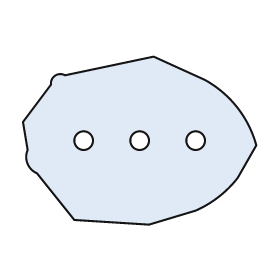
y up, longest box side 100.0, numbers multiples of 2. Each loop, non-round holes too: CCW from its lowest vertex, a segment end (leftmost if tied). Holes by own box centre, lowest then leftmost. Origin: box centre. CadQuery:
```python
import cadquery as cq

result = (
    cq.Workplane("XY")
    .moveTo(4.0, -36.0)
    .lineTo(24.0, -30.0)
    .threePointArc((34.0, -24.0), (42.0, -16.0))
    .lineTo(50.0, -2.0)
    .threePointArc((42.0, 14.0), (28.0, 26.0))
    .lineTo(6.0, 36.0)
    .lineTo(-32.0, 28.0)
    .threePointArc((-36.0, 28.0), (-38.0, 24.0))
    .lineTo(-50.0, 8.0)
    .lineTo(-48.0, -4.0)
    .threePointArc((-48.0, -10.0), (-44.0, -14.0))
    .lineTo(-28.0, -34.0)
    .close()
    .moveTo(-24.0, 0.0)
    .circle(4.0)
    .moveTo(0.0, 0.0)
    .circle(4.0)
    .moveTo(24.0, 0.0)
    .circle(4.0)
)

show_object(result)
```